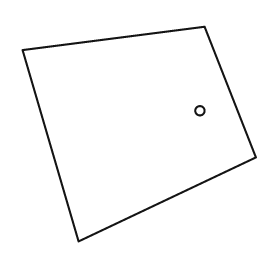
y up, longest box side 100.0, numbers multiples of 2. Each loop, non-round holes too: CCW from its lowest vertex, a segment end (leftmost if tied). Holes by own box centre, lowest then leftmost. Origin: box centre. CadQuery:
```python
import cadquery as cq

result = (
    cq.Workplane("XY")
    .moveTo(-26.0, -46.0)
    .lineTo(50.0, -10.0)
    .lineTo(28.0, 46.0)
    .lineTo(-50.0, 36.0)
    .close()
    .moveTo(26.0, 10.0)
    .circle(2.0)
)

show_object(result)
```